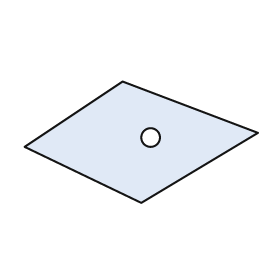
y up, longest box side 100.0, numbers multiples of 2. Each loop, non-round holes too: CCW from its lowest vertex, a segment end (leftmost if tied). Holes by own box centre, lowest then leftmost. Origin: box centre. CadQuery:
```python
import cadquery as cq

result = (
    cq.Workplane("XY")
    .moveTo(0.0, -26.0)
    .lineTo(50.0, 4.0)
    .lineTo(-8.0, 26.0)
    .lineTo(-50.0, -2.0)
    .close()
    .moveTo(4.0, 2.0)
    .circle(4.0)
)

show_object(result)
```